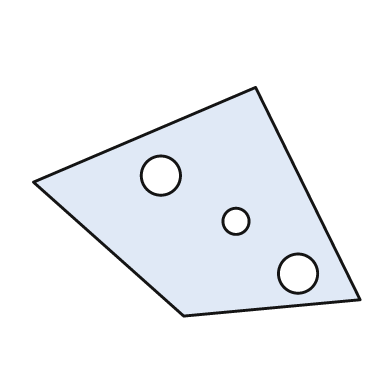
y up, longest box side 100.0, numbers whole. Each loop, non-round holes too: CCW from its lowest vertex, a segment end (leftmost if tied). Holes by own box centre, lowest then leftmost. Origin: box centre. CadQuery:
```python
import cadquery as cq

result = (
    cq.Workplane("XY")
    .moveTo(-4.0, -35.0)
    .lineTo(50.0, -30.0)
    .lineTo(18.0, 35.0)
    .lineTo(-50.0, 6.0)
    .close()
    .moveTo(31.0, -22.0)
    .circle(6.0)
    .moveTo(12.0, -6.0)
    .circle(4.0)
    .moveTo(-11.0, 8.0)
    .circle(6.0)
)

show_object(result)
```